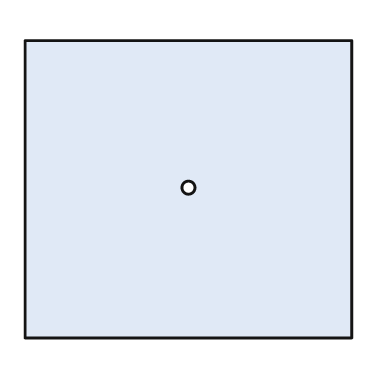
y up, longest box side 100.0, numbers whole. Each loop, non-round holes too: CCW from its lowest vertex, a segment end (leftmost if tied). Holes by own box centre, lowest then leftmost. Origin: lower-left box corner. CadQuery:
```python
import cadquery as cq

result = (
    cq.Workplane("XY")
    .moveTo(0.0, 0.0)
    .lineTo(100.0, 0.0)
    .lineTo(100.0, 91.0)
    .lineTo(0.0, 91.0)
    .close()
    .moveTo(50.0, 46.0)
    .circle(2.0)
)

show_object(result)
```